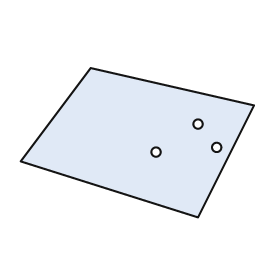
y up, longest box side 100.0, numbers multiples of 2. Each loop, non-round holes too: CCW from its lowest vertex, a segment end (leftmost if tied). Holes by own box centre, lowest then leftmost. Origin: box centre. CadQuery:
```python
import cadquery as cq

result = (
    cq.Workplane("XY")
    .moveTo(26.0, -32.0)
    .lineTo(50.0, 16.0)
    .lineTo(-20.0, 32.0)
    .lineTo(-50.0, -8.0)
    .close()
    .moveTo(8.0, -4.0)
    .circle(2.0)
    .moveTo(34.0, -2.0)
    .circle(2.0)
    .moveTo(26.0, 8.0)
    .circle(2.0)
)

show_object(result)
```